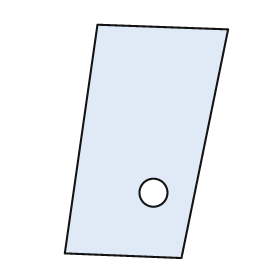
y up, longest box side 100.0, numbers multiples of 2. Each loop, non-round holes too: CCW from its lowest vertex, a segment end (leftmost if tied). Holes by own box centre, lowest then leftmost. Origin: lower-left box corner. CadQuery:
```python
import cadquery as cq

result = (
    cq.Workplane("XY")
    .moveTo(50.0, 0.0)
    .lineTo(70.0, 98.0)
    .lineTo(14.0, 100.0)
    .lineTo(0.0, 2.0)
    .close()
    .moveTo(38.0, 28.0)
    .circle(6.0)
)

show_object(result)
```